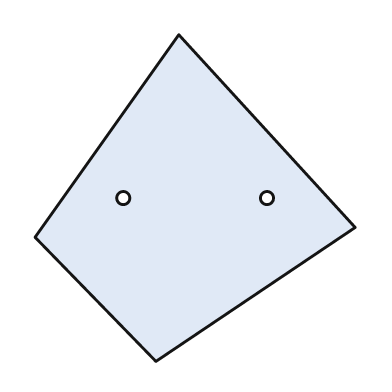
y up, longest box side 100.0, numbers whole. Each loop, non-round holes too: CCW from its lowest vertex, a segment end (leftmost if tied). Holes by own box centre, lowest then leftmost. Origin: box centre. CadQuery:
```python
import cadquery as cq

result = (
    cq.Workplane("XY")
    .moveTo(-12.0, -50.0)
    .lineTo(49.0, -9.0)
    .lineTo(-5.0, 50.0)
    .lineTo(-49.0, -12.0)
    .close()
    .moveTo(-22.0, 0.0)
    .circle(2.0)
    .moveTo(22.0, 0.0)
    .circle(2.0)
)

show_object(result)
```